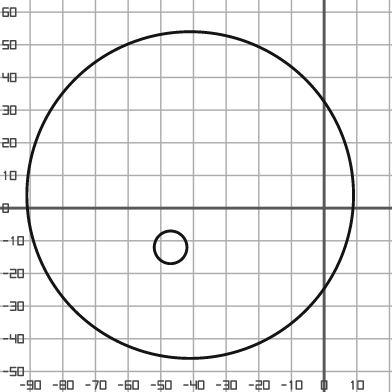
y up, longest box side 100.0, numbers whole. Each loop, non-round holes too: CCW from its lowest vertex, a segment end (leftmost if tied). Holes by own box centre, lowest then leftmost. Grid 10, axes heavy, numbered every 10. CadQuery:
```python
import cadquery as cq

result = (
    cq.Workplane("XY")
    .moveTo(-41.0, 4.0)
    .circle(50.0)
    .moveTo(-47.0, -12.0)
    .circle(5.0)
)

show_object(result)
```